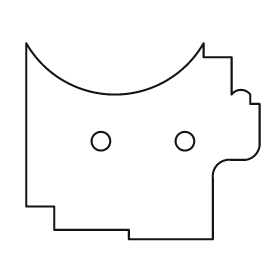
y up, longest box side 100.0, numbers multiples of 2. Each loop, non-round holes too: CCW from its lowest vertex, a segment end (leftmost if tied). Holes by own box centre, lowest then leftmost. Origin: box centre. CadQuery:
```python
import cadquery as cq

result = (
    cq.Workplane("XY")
    .moveTo(-6.0, -42.0)
    .lineTo(30.0, -42.0)
    .lineTo(30.0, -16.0)
    .threePointArc((32.0, -10.0), (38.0, -8.0))
    .lineTo(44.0, -8.0)
    .threePointArc((48.0, -6.0), (50.0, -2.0))
    .lineTo(50.0, 16.0)
    .lineTo(46.0, 16.0)
    .lineTo(46.0, 20.0)
    .threePointArc((42.0, 22.0), (38.0, 20.0))
    .lineTo(38.0, 36.0)
    .lineTo(26.0, 36.0)
    .lineTo(26.0, 42.0)
    .threePointArc((-12.0, 20.0), (-50.0, 42.0))
    .lineTo(-50.0, -28.0)
    .lineTo(-38.0, -28.0)
    .lineTo(-38.0, -38.0)
    .lineTo(-6.0, -38.0)
    .close()
    .moveTo(-18.0, 0.0)
    .circle(4.0)
    .moveTo(18.0, 0.0)
    .circle(4.0)
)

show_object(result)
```